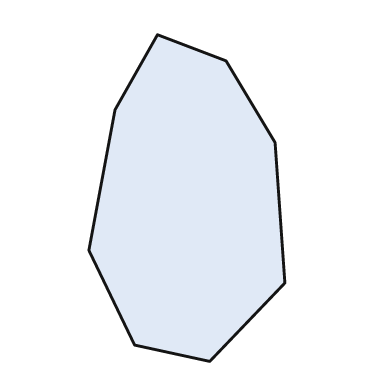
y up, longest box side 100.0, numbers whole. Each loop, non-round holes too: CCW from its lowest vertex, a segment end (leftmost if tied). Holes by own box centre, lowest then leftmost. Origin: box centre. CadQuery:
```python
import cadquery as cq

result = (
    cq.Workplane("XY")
    .moveTo(7.0, -50.0)
    .lineTo(30.0, -26.0)
    .lineTo(27.0, 17.0)
    .lineTo(12.0, 42.0)
    .lineTo(-9.0, 50.0)
    .lineTo(-22.0, 27.0)
    .lineTo(-30.0, -16.0)
    .lineTo(-16.0, -45.0)
    .close()
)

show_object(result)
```